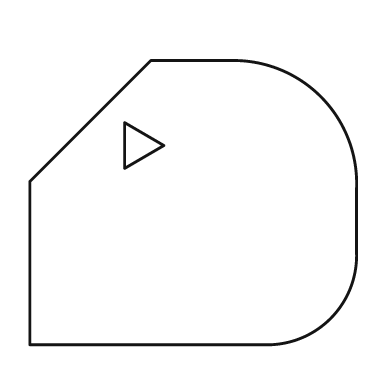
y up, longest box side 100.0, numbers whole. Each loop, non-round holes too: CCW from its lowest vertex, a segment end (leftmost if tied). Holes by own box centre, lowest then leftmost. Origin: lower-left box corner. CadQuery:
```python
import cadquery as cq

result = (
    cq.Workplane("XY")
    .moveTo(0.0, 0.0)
    .lineTo(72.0, 0.0)
    .threePointArc((92.0, 8.0), (100.0, 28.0))
    .lineTo(100.0, 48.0)
    .threePointArc((89.0, 76.0), (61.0, 87.0))
    .lineTo(37.0, 87.0)
    .lineTo(0.0, 50.0)
    .close()
    .moveTo(29.0, 54.0)
    .lineTo(41.0, 61.0)
    .lineTo(29.0, 68.0)
    .close()
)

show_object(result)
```